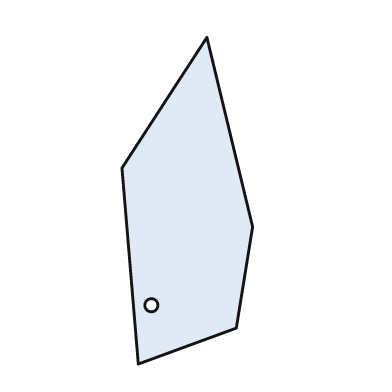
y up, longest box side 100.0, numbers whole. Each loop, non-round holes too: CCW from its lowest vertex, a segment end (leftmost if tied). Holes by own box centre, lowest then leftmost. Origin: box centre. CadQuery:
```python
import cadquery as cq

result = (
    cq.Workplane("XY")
    .moveTo(-15.0, -50.0)
    .lineTo(15.0, -39.0)
    .lineTo(20.0, -8.0)
    .lineTo(6.0, 50.0)
    .lineTo(-20.0, 10.0)
    .close()
    .moveTo(-11.0, -32.0)
    .circle(2.0)
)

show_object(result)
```